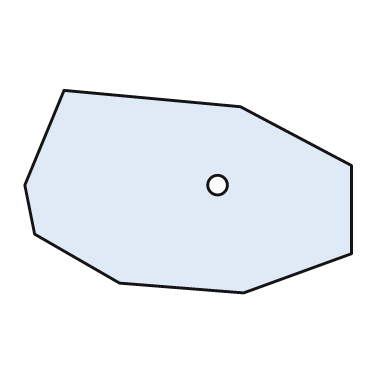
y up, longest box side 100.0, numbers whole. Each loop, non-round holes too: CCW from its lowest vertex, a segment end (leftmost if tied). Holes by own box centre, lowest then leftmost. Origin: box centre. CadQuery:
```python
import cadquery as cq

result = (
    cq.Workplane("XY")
    .moveTo(17.0, -31.0)
    .lineTo(50.0, -19.0)
    .lineTo(50.0, 8.0)
    .lineTo(16.0, 26.0)
    .lineTo(-38.0, 31.0)
    .lineTo(-50.0, 2.0)
    .lineTo(-47.0, -13.0)
    .lineTo(-21.0, -28.0)
    .close()
    .moveTo(9.0, 2.0)
    .circle(3.0)
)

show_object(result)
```